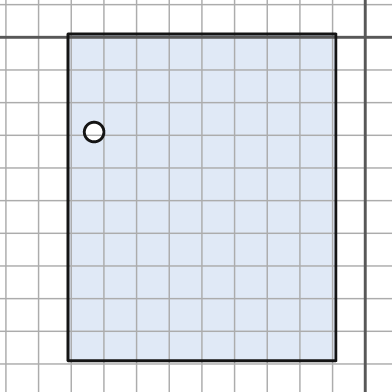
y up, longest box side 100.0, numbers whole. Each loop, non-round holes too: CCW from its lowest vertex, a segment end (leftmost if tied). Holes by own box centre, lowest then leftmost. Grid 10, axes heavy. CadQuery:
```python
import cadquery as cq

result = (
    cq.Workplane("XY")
    .moveTo(-91.0, -99.0)
    .lineTo(-9.0, -99.0)
    .lineTo(-9.0, 1.0)
    .lineTo(-91.0, 1.0)
    .close()
    .moveTo(-83.0, -29.0)
    .circle(3.0)
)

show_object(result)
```